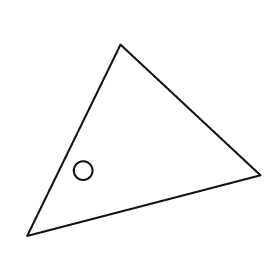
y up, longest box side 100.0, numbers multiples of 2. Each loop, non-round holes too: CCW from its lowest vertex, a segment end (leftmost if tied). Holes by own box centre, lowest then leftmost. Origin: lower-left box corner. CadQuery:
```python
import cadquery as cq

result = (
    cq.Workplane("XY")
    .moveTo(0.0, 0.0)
    .lineTo(100.0, 26.0)
    .lineTo(40.0, 82.0)
    .close()
    .moveTo(24.0, 28.0)
    .circle(4.0)
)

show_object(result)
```